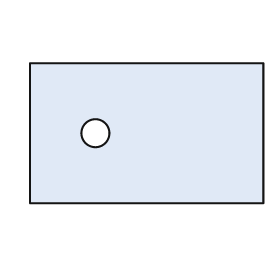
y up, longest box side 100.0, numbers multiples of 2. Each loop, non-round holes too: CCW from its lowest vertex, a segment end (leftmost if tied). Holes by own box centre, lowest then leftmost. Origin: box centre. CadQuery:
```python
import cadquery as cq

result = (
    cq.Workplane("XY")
    .moveTo(-50.0, -30.0)
    .lineTo(50.0, -30.0)
    .lineTo(50.0, 30.0)
    .lineTo(-50.0, 30.0)
    .close()
    .moveTo(-22.0, 0.0)
    .circle(6.0)
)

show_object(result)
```